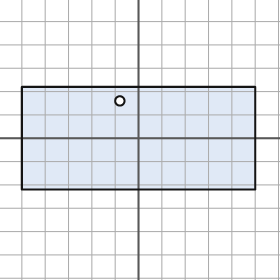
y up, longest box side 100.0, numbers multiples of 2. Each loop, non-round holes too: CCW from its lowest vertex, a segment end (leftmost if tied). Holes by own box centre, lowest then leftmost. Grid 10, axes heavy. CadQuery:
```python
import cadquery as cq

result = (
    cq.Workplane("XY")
    .moveTo(-50.0, -22.0)
    .lineTo(50.0, -22.0)
    .lineTo(50.0, 22.0)
    .lineTo(-50.0, 22.0)
    .close()
    .moveTo(-8.0, 16.0)
    .circle(2.0)
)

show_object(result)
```